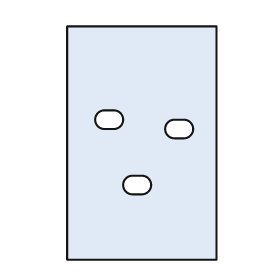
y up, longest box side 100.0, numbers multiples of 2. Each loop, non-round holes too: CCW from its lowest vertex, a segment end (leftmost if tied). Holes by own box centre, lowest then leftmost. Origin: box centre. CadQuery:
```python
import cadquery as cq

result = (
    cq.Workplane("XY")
    .moveTo(-32.0, -50.0)
    .lineTo(32.0, -50.0)
    .lineTo(32.0, 50.0)
    .lineTo(-32.0, 50.0)
    .close()
    .moveTo(-4.0, -22.0)
    .lineTo(0.0, -22.0)
    .threePointArc((4.0, -18.0), (0.0, -14.0))
    .lineTo(-4.0, -14.0)
    .threePointArc((-8.0, -18.0), (-4.0, -22.0))
    .close()
    .moveTo(14.0, 2.0)
    .lineTo(18.0, 2.0)
    .threePointArc((22.0, 6.0), (18.0, 10.0))
    .lineTo(14.0, 10.0)
    .threePointArc((10.0, 6.0), (14.0, 2.0))
    .close()
    .moveTo(-16.0, 6.0)
    .lineTo(-12.0, 6.0)
    .threePointArc((-8.0, 10.0), (-12.0, 14.0))
    .lineTo(-16.0, 14.0)
    .threePointArc((-20.0, 10.0), (-16.0, 6.0))
    .close()
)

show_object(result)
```